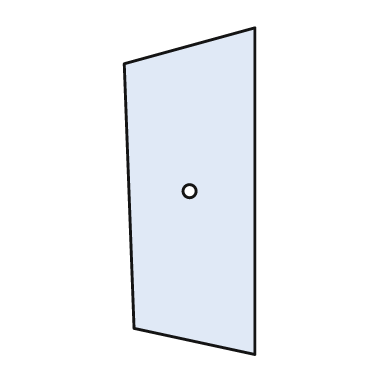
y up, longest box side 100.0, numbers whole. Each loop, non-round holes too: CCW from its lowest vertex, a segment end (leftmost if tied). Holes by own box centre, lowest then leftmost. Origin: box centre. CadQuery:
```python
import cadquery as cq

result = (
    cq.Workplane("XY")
    .moveTo(20.0, -50.0)
    .lineTo(20.0, 50.0)
    .lineTo(-20.0, 39.0)
    .lineTo(-17.0, -42.0)
    .close()
    .moveTo(0.0, 0.0)
    .circle(2.0)
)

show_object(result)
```